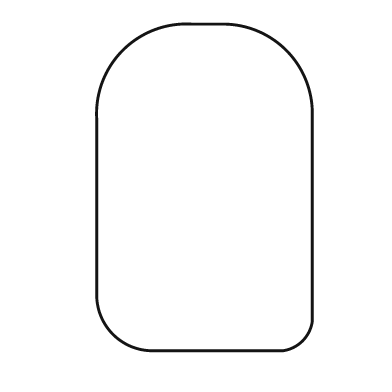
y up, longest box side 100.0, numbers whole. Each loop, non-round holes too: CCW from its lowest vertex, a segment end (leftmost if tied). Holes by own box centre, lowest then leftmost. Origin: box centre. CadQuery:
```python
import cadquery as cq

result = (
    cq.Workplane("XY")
    .moveTo(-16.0, -50.0)
    .lineTo(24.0, -50.0)
    .threePointArc((30.0, -47.0), (33.0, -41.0))
    .lineTo(33.0, 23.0)
    .threePointArc((25.0, 42.0), (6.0, 50.0))
    .lineTo(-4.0, 50.0)
    .threePointArc((-25.0, 42.0), (-33.0, 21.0))
    .lineTo(-33.0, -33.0)
    .threePointArc((-28.0, -45.0), (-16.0, -50.0))
    .close()
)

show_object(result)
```